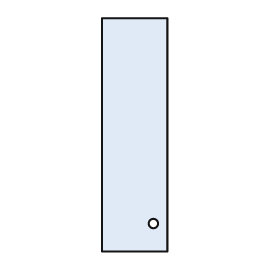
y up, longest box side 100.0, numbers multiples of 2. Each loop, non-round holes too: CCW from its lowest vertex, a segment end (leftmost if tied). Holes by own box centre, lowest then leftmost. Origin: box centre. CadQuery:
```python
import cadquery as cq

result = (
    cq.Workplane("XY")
    .moveTo(-14.0, -50.0)
    .lineTo(14.0, -50.0)
    .lineTo(14.0, 50.0)
    .lineTo(-14.0, 50.0)
    .close()
    .moveTo(8.0, -38.0)
    .circle(2.0)
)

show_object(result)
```